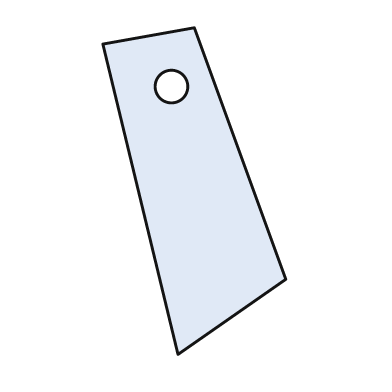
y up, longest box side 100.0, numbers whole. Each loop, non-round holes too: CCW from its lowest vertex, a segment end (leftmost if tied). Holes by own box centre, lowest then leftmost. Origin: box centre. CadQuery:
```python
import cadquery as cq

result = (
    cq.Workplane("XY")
    .moveTo(-5.0, -50.0)
    .lineTo(28.0, -27.0)
    .lineTo(0.0, 50.0)
    .lineTo(-28.0, 45.0)
    .close()
    .moveTo(-7.0, 32.0)
    .circle(5.0)
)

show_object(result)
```